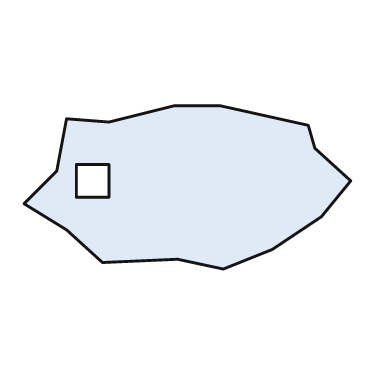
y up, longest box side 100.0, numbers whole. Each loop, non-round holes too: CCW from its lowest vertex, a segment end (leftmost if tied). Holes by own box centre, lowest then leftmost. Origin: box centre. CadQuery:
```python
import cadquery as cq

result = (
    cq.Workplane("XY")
    .moveTo(11.0, -25.0)
    .lineTo(26.0, -19.0)
    .lineTo(41.0, -9.0)
    .lineTo(50.0, 2.0)
    .lineTo(39.0, 12.0)
    .lineTo(37.0, 19.0)
    .lineTo(10.0, 25.0)
    .lineTo(-4.0, 25.0)
    .lineTo(-24.0, 20.0)
    .lineTo(-37.0, 21.0)
    .lineTo(-40.0, 5.0)
    .lineTo(-50.0, -5.0)
    .lineTo(-37.0, -13.0)
    .lineTo(-26.0, -23.0)
    .lineTo(-3.0, -22.0)
    .close()
    .moveTo(-34.0, -3.0)
    .lineTo(-24.0, -3.0)
    .lineTo(-24.0, 7.0)
    .lineTo(-34.0, 7.0)
    .close()
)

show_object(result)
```